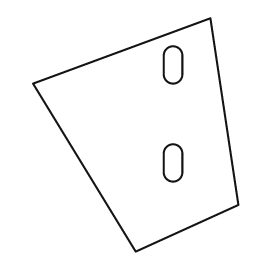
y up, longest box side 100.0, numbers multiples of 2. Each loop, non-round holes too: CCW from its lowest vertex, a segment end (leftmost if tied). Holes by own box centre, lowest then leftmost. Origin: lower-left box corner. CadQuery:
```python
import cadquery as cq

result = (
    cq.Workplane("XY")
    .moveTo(44.0, 0.0)
    .lineTo(88.0, 20.0)
    .lineTo(76.0, 100.0)
    .lineTo(0.0, 72.0)
    .close()
    .moveTo(56.0, 34.0)
    .threePointArc((60.0, 30.0), (64.0, 34.0))
    .lineTo(64.0, 42.0)
    .threePointArc((60.0, 46.0), (56.0, 42.0))
    .close()
    .moveTo(56.0, 76.0)
    .threePointArc((60.0, 72.0), (64.0, 76.0))
    .lineTo(64.0, 84.0)
    .threePointArc((60.0, 88.0), (56.0, 84.0))
    .close()
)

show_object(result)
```